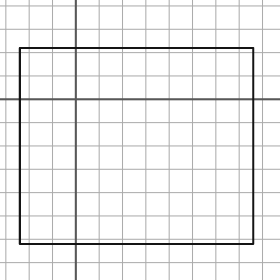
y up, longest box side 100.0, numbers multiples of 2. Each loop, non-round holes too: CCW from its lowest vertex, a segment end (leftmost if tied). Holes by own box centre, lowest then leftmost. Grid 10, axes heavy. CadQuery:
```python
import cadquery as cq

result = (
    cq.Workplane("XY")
    .moveTo(-24.0, -62.0)
    .lineTo(76.0, -62.0)
    .lineTo(76.0, 22.0)
    .lineTo(-24.0, 22.0)
    .close()
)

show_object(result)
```